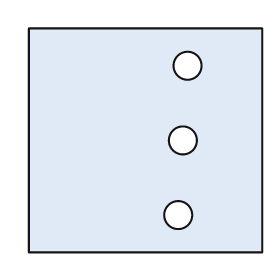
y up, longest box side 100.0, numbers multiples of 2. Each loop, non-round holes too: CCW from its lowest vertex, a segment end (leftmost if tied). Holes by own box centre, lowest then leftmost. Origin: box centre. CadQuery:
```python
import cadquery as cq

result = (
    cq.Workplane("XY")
    .moveTo(-50.0, -48.0)
    .lineTo(50.0, -48.0)
    .lineTo(50.0, 48.0)
    .lineTo(-50.0, 48.0)
    .close()
    .moveTo(14.0, -32.0)
    .circle(6.0)
    .moveTo(16.0, 0.0)
    .circle(6.0)
    .moveTo(18.0, 32.0)
    .circle(6.0)
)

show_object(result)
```